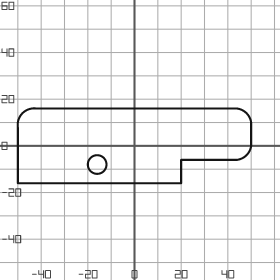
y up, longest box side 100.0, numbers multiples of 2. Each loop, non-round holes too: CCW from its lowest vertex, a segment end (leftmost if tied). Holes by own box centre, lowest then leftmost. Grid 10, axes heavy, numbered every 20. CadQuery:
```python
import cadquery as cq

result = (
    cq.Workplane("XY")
    .moveTo(-50.0, -16.0)
    .lineTo(20.0, -16.0)
    .lineTo(20.0, -6.0)
    .lineTo(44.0, -6.0)
    .threePointArc((48.0, -4.0), (50.0, 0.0))
    .lineTo(50.0, 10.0)
    .threePointArc((48.0, 14.0), (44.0, 16.0))
    .lineTo(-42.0, 16.0)
    .threePointArc((-48.0, 14.0), (-50.0, 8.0))
    .close()
    .moveTo(-16.0, -8.0)
    .circle(4.0)
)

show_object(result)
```